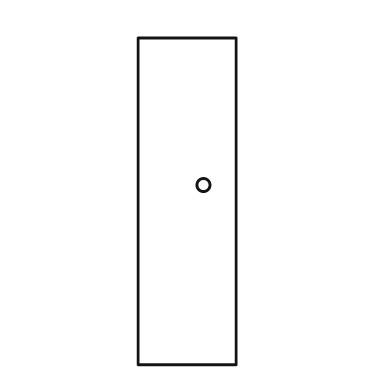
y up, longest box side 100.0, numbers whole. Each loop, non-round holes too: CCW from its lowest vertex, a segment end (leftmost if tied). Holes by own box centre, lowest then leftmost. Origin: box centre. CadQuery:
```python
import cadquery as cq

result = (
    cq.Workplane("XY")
    .moveTo(-15.0, -50.0)
    .lineTo(15.0, -50.0)
    .lineTo(15.0, 50.0)
    .lineTo(-15.0, 50.0)
    .close()
    .moveTo(5.0, 5.0)
    .circle(2.0)
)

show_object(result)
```